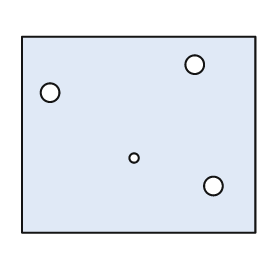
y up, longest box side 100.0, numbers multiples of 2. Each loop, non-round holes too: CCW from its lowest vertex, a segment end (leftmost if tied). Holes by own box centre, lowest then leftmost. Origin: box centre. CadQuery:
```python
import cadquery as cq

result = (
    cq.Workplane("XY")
    .moveTo(-50.0, -42.0)
    .lineTo(50.0, -42.0)
    .lineTo(50.0, 42.0)
    .lineTo(-50.0, 42.0)
    .close()
    .moveTo(32.0, -22.0)
    .circle(4.0)
    .moveTo(-2.0, -10.0)
    .circle(2.0)
    .moveTo(-38.0, 18.0)
    .circle(4.0)
    .moveTo(24.0, 30.0)
    .circle(4.0)
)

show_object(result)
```